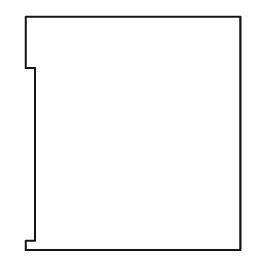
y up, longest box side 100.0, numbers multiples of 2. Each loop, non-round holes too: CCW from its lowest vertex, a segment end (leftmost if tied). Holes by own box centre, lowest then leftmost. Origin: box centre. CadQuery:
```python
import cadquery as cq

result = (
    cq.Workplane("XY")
    .moveTo(-46.0, -50.0)
    .lineTo(46.0, -50.0)
    .lineTo(46.0, 50.0)
    .lineTo(-46.0, 50.0)
    .lineTo(-46.0, 28.0)
    .lineTo(-42.0, 28.0)
    .lineTo(-42.0, -46.0)
    .lineTo(-46.0, -46.0)
    .close()
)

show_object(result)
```